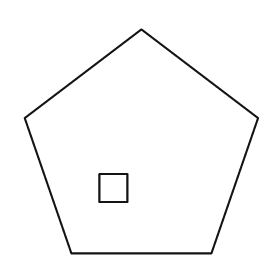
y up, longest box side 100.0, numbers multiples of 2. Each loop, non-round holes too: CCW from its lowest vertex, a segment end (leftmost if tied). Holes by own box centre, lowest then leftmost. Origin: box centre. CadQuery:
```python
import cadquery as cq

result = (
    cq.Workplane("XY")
    .moveTo(-30.0, -48.0)
    .lineTo(30.0, -48.0)
    .lineTo(50.0, 10.0)
    .lineTo(0.0, 48.0)
    .lineTo(-50.0, 10.0)
    .close()
    .moveTo(-18.0, -26.0)
    .lineTo(-6.0, -26.0)
    .lineTo(-6.0, -14.0)
    .lineTo(-18.0, -14.0)
    .close()
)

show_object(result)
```